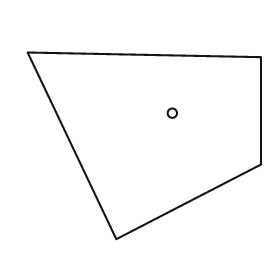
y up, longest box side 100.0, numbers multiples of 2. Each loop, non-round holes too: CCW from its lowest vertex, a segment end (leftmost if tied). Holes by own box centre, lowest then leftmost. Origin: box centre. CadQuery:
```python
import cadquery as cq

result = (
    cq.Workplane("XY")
    .moveTo(-12.0, -40.0)
    .lineTo(50.0, -8.0)
    .lineTo(50.0, 38.0)
    .lineTo(-50.0, 40.0)
    .close()
    .moveTo(12.0, 14.0)
    .circle(2.0)
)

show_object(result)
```